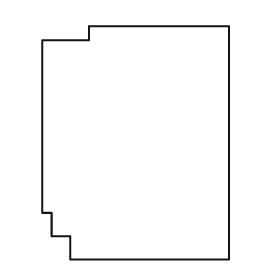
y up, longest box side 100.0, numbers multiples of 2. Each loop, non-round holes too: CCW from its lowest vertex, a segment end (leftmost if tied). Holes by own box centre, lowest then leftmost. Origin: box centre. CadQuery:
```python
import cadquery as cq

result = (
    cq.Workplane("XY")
    .moveTo(-28.0, -50.0)
    .lineTo(40.0, -50.0)
    .lineTo(40.0, 50.0)
    .lineTo(-20.0, 50.0)
    .lineTo(-20.0, 44.0)
    .lineTo(-40.0, 44.0)
    .lineTo(-40.0, -30.0)
    .lineTo(-36.0, -30.0)
    .lineTo(-36.0, -40.0)
    .lineTo(-28.0, -40.0)
    .close()
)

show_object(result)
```